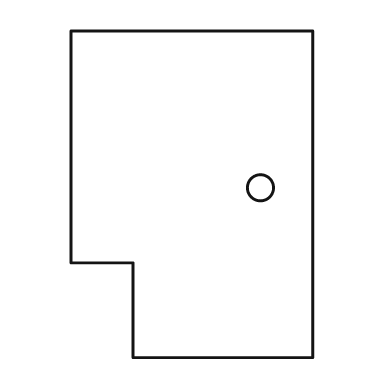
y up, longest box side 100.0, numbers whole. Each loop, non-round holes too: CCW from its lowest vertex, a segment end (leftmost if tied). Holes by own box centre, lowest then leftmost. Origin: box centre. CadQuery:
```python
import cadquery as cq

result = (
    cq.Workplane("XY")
    .moveTo(-18.0, -50.0)
    .lineTo(37.0, -50.0)
    .lineTo(37.0, 50.0)
    .lineTo(-37.0, 50.0)
    .lineTo(-37.0, -21.0)
    .lineTo(-18.0, -21.0)
    .close()
    .moveTo(21.0, 2.0)
    .circle(4.0)
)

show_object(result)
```